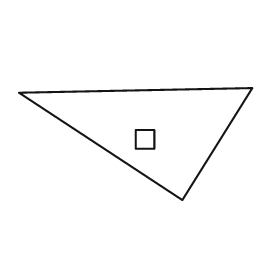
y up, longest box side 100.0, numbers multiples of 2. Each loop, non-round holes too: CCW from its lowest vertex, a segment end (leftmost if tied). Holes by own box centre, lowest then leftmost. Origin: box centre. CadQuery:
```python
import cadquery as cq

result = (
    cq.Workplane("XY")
    .moveTo(20.0, -24.0)
    .lineTo(50.0, 24.0)
    .lineTo(-50.0, 22.0)
    .close()
    .moveTo(0.0, -2.0)
    .lineTo(8.0, -2.0)
    .lineTo(8.0, 6.0)
    .lineTo(0.0, 6.0)
    .close()
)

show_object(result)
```